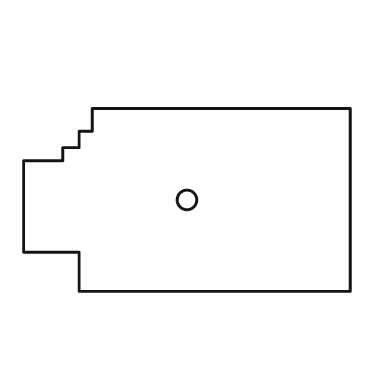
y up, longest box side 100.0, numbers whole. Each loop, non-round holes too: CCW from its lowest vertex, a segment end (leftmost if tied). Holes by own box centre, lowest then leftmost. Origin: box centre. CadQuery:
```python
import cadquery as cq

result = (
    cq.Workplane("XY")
    .moveTo(-33.0, -28.0)
    .lineTo(50.0, -28.0)
    .lineTo(50.0, 28.0)
    .lineTo(-29.0, 28.0)
    .lineTo(-29.0, 21.0)
    .lineTo(-33.0, 21.0)
    .lineTo(-33.0, 16.0)
    .lineTo(-38.0, 16.0)
    .lineTo(-38.0, 12.0)
    .lineTo(-50.0, 12.0)
    .lineTo(-50.0, -16.0)
    .lineTo(-33.0, -16.0)
    .close()
    .moveTo(0.0, 0.0)
    .circle(3.0)
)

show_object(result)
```